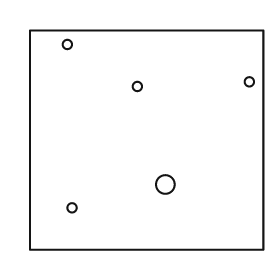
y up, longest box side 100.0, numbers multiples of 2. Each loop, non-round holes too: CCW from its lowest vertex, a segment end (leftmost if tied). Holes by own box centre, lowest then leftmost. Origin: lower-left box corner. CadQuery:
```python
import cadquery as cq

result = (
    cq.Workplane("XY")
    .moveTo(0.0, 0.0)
    .lineTo(100.0, 0.0)
    .lineTo(100.0, 94.0)
    .lineTo(0.0, 94.0)
    .close()
    .moveTo(18.0, 18.0)
    .circle(2.0)
    .moveTo(58.0, 28.0)
    .circle(4.0)
    .moveTo(46.0, 70.0)
    .circle(2.0)
    .moveTo(94.0, 72.0)
    .circle(2.0)
    .moveTo(16.0, 88.0)
    .circle(2.0)
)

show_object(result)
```